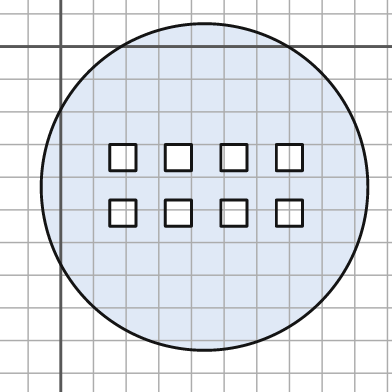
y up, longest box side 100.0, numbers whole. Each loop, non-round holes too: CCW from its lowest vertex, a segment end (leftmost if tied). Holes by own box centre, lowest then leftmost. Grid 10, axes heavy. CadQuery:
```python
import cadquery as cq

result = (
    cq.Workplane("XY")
    .moveTo(44.0, -43.0)
    .circle(50.0)
    .moveTo(15.0, -55.0)
    .lineTo(23.0, -55.0)
    .lineTo(23.0, -47.0)
    .lineTo(15.0, -47.0)
    .close()
    .moveTo(32.0, -55.0)
    .lineTo(40.0, -55.0)
    .lineTo(40.0, -47.0)
    .lineTo(32.0, -47.0)
    .close()
    .moveTo(49.0, -55.0)
    .lineTo(57.0, -55.0)
    .lineTo(57.0, -47.0)
    .lineTo(49.0, -47.0)
    .close()
    .moveTo(66.0, -55.0)
    .lineTo(74.0, -55.0)
    .lineTo(74.0, -47.0)
    .lineTo(66.0, -47.0)
    .close()
    .moveTo(15.0, -38.0)
    .lineTo(23.0, -38.0)
    .lineTo(23.0, -30.0)
    .lineTo(15.0, -30.0)
    .close()
    .moveTo(32.0, -38.0)
    .lineTo(40.0, -38.0)
    .lineTo(40.0, -30.0)
    .lineTo(32.0, -30.0)
    .close()
    .moveTo(49.0, -38.0)
    .lineTo(57.0, -38.0)
    .lineTo(57.0, -30.0)
    .lineTo(49.0, -30.0)
    .close()
    .moveTo(66.0, -38.0)
    .lineTo(74.0, -38.0)
    .lineTo(74.0, -30.0)
    .lineTo(66.0, -30.0)
    .close()
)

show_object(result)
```